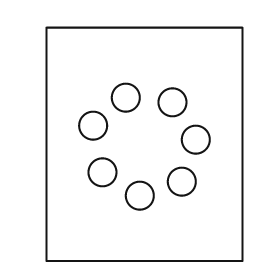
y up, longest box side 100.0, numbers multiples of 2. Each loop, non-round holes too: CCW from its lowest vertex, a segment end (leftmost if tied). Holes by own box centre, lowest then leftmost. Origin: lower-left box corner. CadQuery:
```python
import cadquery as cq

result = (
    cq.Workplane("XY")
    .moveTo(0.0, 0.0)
    .lineTo(84.0, 0.0)
    .lineTo(84.0, 100.0)
    .lineTo(0.0, 100.0)
    .close()
    .moveTo(40.0, 28.0)
    .circle(6.0)
    .moveTo(58.0, 34.0)
    .circle(6.0)
    .moveTo(24.0, 38.0)
    .circle(6.0)
    .moveTo(64.0, 52.0)
    .circle(6.0)
    .moveTo(20.0, 58.0)
    .circle(6.0)
    .moveTo(54.0, 68.0)
    .circle(6.0)
    .moveTo(34.0, 70.0)
    .circle(6.0)
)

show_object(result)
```